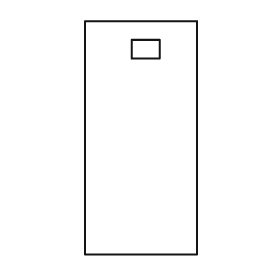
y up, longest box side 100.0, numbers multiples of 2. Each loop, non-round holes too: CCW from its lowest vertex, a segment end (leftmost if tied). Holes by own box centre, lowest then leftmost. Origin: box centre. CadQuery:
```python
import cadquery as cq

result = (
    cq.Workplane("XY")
    .moveTo(-24.0, -50.0)
    .lineTo(24.0, -50.0)
    .lineTo(24.0, 50.0)
    .lineTo(-24.0, 50.0)
    .close()
    .moveTo(-4.0, 34.0)
    .lineTo(8.0, 34.0)
    .lineTo(8.0, 42.0)
    .lineTo(-4.0, 42.0)
    .close()
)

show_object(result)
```